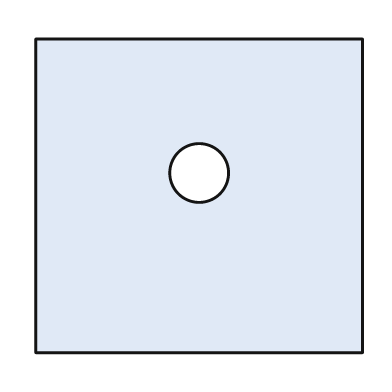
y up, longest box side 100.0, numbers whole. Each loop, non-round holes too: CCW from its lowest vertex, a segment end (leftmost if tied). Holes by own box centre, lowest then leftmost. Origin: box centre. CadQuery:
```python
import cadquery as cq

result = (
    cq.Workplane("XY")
    .moveTo(-50.0, -48.0)
    .lineTo(50.0, -48.0)
    .lineTo(50.0, 48.0)
    .lineTo(-50.0, 48.0)
    .close()
    .moveTo(0.0, 7.0)
    .circle(9.0)
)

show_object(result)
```